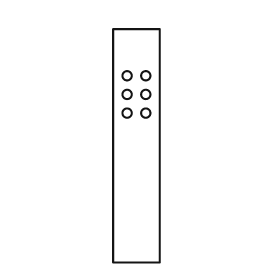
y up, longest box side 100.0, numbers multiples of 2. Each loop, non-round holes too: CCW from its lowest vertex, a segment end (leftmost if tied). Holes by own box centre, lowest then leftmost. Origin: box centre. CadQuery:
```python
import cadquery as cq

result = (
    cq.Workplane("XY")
    .moveTo(-10.0, -50.0)
    .lineTo(10.0, -50.0)
    .lineTo(10.0, 50.0)
    .lineTo(-10.0, 50.0)
    .close()
    .moveTo(-4.0, 14.0)
    .circle(2.0)
    .moveTo(4.0, 14.0)
    .circle(2.0)
    .moveTo(-4.0, 22.0)
    .circle(2.0)
    .moveTo(4.0, 22.0)
    .circle(2.0)
    .moveTo(-4.0, 30.0)
    .circle(2.0)
    .moveTo(4.0, 30.0)
    .circle(2.0)
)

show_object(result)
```